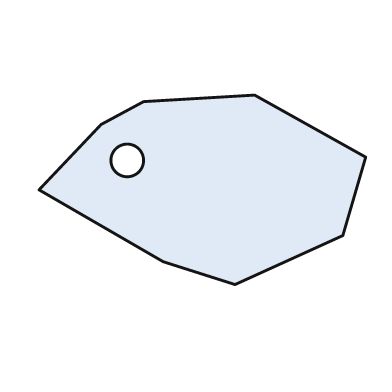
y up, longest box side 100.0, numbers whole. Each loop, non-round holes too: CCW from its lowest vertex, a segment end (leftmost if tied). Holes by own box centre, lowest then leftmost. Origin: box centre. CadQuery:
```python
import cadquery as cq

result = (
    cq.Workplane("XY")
    .moveTo(10.0, -29.0)
    .lineTo(43.0, -14.0)
    .lineTo(50.0, 10.0)
    .lineTo(16.0, 29.0)
    .lineTo(-18.0, 27.0)
    .lineTo(-31.0, 20.0)
    .lineTo(-50.0, 0.0)
    .lineTo(-12.0, -22.0)
    .close()
    .moveTo(-23.0, 9.0)
    .circle(5.0)
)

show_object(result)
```